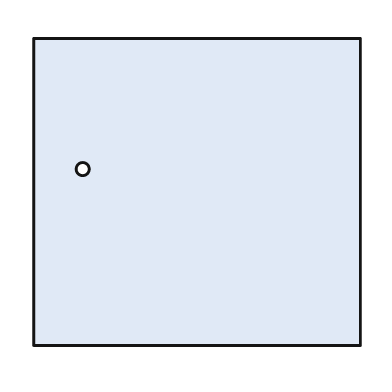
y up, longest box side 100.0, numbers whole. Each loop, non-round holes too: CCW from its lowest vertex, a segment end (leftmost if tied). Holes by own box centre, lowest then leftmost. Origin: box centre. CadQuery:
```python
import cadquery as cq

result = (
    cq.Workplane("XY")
    .moveTo(-50.0, -47.0)
    .lineTo(50.0, -47.0)
    .lineTo(50.0, 47.0)
    .lineTo(-50.0, 47.0)
    .close()
    .moveTo(-35.0, 7.0)
    .circle(2.0)
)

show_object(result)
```